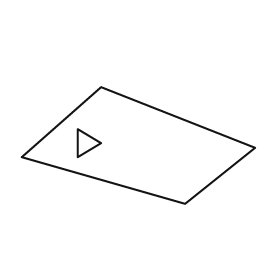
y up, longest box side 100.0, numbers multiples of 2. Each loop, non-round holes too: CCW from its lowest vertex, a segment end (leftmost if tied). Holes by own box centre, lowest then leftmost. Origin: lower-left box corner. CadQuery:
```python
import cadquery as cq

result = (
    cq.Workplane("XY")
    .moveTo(70.0, 0.0)
    .lineTo(100.0, 24.0)
    .lineTo(34.0, 50.0)
    .lineTo(0.0, 20.0)
    .close()
    .moveTo(24.0, 20.0)
    .lineTo(34.0, 26.0)
    .lineTo(24.0, 32.0)
    .close()
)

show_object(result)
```